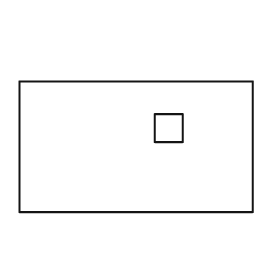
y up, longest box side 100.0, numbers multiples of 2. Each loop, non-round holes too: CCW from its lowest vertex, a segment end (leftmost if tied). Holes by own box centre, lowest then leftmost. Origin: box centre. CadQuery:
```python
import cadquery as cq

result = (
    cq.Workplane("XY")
    .moveTo(-50.0, -28.0)
    .lineTo(50.0, -28.0)
    .lineTo(50.0, 28.0)
    .lineTo(-50.0, 28.0)
    .close()
    .moveTo(8.0, 2.0)
    .lineTo(20.0, 2.0)
    .lineTo(20.0, 14.0)
    .lineTo(8.0, 14.0)
    .close()
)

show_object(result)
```